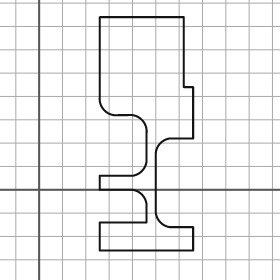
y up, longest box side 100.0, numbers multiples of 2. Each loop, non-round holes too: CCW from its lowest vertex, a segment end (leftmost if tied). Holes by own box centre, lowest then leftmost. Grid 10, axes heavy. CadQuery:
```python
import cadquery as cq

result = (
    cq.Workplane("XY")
    .moveTo(26.0, -26.0)
    .lineTo(66.0, -26.0)
    .lineTo(66.0, -16.0)
    .lineTo(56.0, -16.0)
    .threePointArc((52.0, -14.0), (50.0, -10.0))
    .lineTo(50.0, 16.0)
    .threePointArc((52.0, 20.0), (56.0, 22.0))
    .lineTo(66.0, 22.0)
    .lineTo(66.0, 44.0)
    .lineTo(62.0, 44.0)
    .lineTo(62.0, 74.0)
    .lineTo(26.0, 74.0)
    .lineTo(26.0, 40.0)
    .threePointArc((28.0, 34.0), (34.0, 32.0))
    .lineTo(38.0, 32.0)
    .threePointArc((44.0, 30.0), (46.0, 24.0))
    .lineTo(46.0, 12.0)
    .threePointArc((44.0, 8.0), (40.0, 6.0))
    .lineTo(26.0, 6.0)
    .lineTo(26.0, 0.0)
    .lineTo(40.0, 0.0)
    .threePointArc((44.0, -2.0), (46.0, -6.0))
    .lineTo(46.0, -14.0)
    .lineTo(26.0, -14.0)
    .close()
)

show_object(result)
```